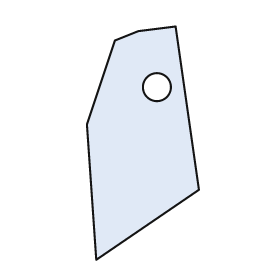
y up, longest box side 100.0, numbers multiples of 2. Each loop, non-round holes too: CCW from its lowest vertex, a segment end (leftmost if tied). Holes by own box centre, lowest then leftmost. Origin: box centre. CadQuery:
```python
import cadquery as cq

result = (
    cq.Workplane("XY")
    .moveTo(-20.0, -50.0)
    .lineTo(24.0, -20.0)
    .lineTo(14.0, 50.0)
    .lineTo(-2.0, 48.0)
    .lineTo(-12.0, 44.0)
    .lineTo(-24.0, 8.0)
    .close()
    .moveTo(6.0, 24.0)
    .circle(6.0)
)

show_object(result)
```